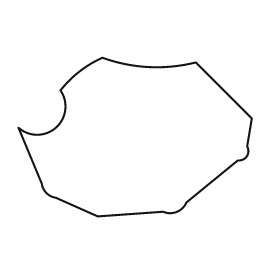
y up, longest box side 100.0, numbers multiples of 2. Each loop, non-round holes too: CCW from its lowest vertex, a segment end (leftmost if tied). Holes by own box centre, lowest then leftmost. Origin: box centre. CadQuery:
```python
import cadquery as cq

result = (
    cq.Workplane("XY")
    .moveTo(-16.0, -34.0)
    .lineTo(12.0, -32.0)
    .threePointArc((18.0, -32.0), (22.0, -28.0))
    .lineTo(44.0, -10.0)
    .threePointArc((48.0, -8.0), (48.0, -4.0))
    .lineTo(50.0, 8.0)
    .lineTo(26.0, 32.0)
    .threePointArc((6.0, 30.0), (-14.0, 34.0))
    .threePointArc((-24.0, 28.0), (-32.0, 20.0))
    .threePointArc((-34.0, 4.0), (-50.0, 4.0))
    .lineTo(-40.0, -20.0)
    .threePointArc((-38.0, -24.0), (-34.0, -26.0))
    .close()
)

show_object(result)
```